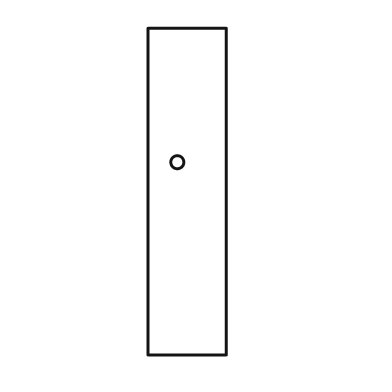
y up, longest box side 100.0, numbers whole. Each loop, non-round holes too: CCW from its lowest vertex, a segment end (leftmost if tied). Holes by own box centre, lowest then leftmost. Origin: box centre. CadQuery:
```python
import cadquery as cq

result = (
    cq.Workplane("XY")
    .moveTo(-12.0, -50.0)
    .lineTo(12.0, -50.0)
    .lineTo(12.0, 50.0)
    .lineTo(-12.0, 50.0)
    .close()
    .moveTo(-3.0, 9.0)
    .circle(2.0)
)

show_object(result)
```